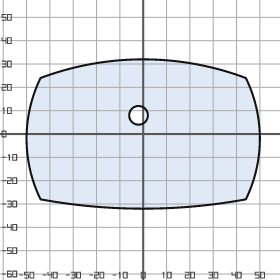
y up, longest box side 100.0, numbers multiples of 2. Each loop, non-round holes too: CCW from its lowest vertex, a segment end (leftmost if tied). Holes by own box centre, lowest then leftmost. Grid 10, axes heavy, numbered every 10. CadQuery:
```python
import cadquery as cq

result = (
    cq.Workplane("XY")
    .moveTo(-44.0, -28.0)
    .threePointArc((0.0, -32.0), (44.0, -28.0))
    .threePointArc((50.0, -2.0), (44.0, 24.0))
    .threePointArc((0.0, 32.0), (-44.0, 24.0))
    .threePointArc((-50.0, -2.0), (-44.0, -28.0))
    .close()
    .moveTo(-2.0, 8.0)
    .circle(4.0)
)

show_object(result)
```